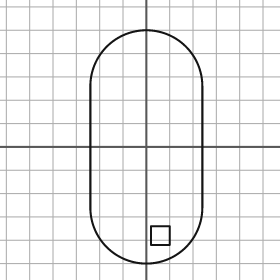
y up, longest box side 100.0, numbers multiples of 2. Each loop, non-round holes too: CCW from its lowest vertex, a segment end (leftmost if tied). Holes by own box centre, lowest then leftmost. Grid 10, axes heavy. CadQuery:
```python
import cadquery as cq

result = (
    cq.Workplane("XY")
    .moveTo(-24.0, -26.0)
    .threePointArc((0.0, -50.0), (24.0, -26.0))
    .lineTo(24.0, 26.0)
    .threePointArc((0.0, 50.0), (-24.0, 26.0))
    .close()
    .moveTo(2.0, -42.0)
    .lineTo(10.0, -42.0)
    .lineTo(10.0, -34.0)
    .lineTo(2.0, -34.0)
    .close()
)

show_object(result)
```